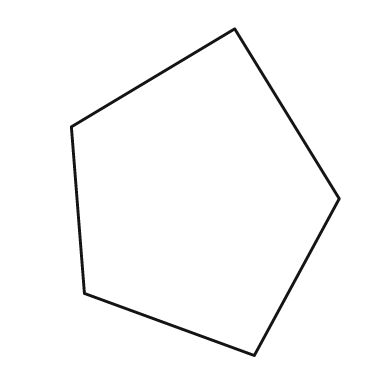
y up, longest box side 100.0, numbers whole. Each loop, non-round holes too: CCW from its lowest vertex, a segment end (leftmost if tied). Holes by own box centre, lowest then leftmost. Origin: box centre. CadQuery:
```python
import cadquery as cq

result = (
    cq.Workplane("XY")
    .moveTo(15.0, -50.0)
    .lineTo(41.0, -2.0)
    .lineTo(9.0, 50.0)
    .lineTo(-41.0, 20.0)
    .lineTo(-37.0, -31.0)
    .close()
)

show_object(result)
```